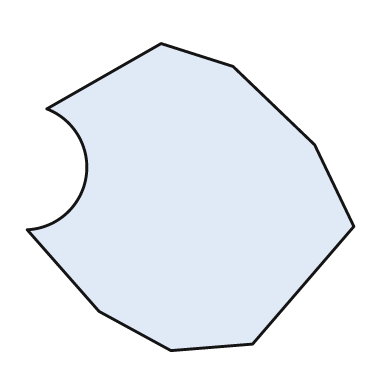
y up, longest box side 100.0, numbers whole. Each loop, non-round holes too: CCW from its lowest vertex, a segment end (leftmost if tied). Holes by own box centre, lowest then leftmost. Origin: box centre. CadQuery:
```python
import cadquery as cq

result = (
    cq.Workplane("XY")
    .moveTo(-6.0, -47.0)
    .lineTo(19.0, -45.0)
    .lineTo(50.0, -9.0)
    .lineTo(38.0, 16.0)
    .lineTo(13.0, 40.0)
    .lineTo(-9.0, 47.0)
    .lineTo(-44.0, 27.0)
    .threePointArc((-32.0, 6.0), (-50.0, -10.0))
    .lineTo(-28.0, -35.0)
    .close()
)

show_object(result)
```